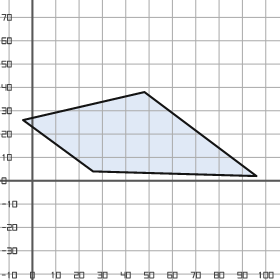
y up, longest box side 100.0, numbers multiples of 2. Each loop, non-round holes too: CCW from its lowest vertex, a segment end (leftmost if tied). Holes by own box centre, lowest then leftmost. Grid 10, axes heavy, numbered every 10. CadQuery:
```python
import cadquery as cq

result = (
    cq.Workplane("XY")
    .moveTo(96.0, 2.0)
    .lineTo(48.0, 38.0)
    .lineTo(-4.0, 26.0)
    .lineTo(26.0, 4.0)
    .close()
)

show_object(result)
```